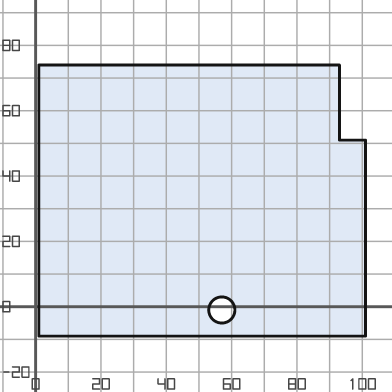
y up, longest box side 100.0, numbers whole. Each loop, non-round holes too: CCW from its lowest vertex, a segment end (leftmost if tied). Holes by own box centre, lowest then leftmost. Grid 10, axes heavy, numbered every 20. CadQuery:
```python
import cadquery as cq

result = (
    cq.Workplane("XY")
    .moveTo(1.0, -9.0)
    .lineTo(101.0, -9.0)
    .lineTo(101.0, 51.0)
    .lineTo(93.0, 51.0)
    .lineTo(93.0, 74.0)
    .lineTo(1.0, 74.0)
    .close()
    .moveTo(57.0, -1.0)
    .circle(4.0)
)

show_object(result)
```